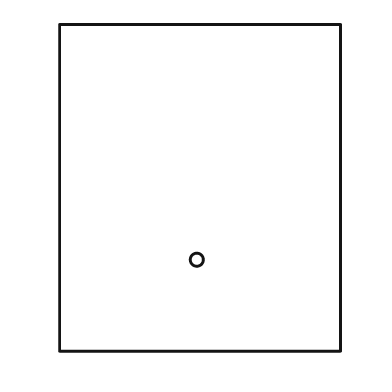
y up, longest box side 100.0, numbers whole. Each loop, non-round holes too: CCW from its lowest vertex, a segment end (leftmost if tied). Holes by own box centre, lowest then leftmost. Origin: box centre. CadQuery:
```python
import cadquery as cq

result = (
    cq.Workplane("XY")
    .moveTo(-43.0, -50.0)
    .lineTo(43.0, -50.0)
    .lineTo(43.0, 50.0)
    .lineTo(-43.0, 50.0)
    .close()
    .moveTo(-1.0, -22.0)
    .circle(2.0)
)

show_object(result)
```